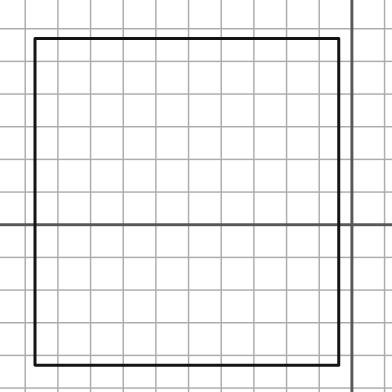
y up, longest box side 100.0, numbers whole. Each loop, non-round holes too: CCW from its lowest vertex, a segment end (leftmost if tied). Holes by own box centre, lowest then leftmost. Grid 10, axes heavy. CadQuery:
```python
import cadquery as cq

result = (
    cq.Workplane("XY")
    .moveTo(-97.0, -43.0)
    .lineTo(-4.0, -43.0)
    .lineTo(-4.0, 57.0)
    .lineTo(-97.0, 57.0)
    .close()
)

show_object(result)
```